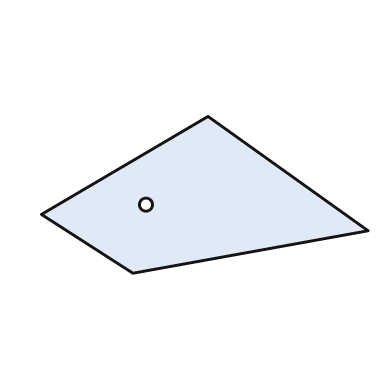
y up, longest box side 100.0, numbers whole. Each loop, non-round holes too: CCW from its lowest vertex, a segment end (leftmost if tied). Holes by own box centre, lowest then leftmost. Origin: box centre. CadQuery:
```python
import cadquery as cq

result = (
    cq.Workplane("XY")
    .moveTo(-22.0, -24.0)
    .lineTo(50.0, -11.0)
    .lineTo(1.0, 24.0)
    .lineTo(-50.0, -6.0)
    .close()
    .moveTo(-18.0, -3.0)
    .circle(2.0)
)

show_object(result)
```